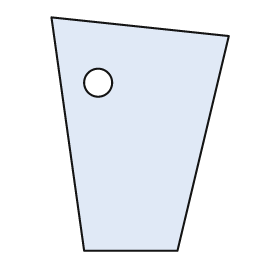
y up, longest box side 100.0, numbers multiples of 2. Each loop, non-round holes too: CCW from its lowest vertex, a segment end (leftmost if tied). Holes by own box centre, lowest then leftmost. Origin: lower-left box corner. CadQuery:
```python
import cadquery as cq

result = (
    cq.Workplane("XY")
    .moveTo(14.0, 0.0)
    .lineTo(54.0, 0.0)
    .lineTo(76.0, 92.0)
    .lineTo(0.0, 100.0)
    .close()
    .moveTo(20.0, 72.0)
    .circle(6.0)
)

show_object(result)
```